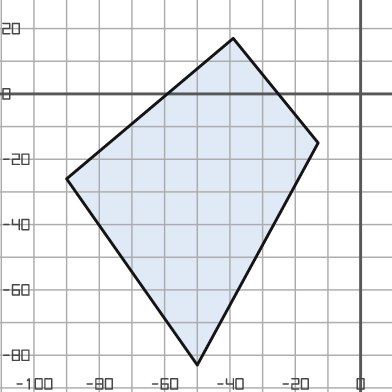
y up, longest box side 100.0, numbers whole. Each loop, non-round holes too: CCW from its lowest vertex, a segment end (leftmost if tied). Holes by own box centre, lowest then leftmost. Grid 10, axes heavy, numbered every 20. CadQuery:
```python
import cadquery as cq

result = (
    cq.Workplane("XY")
    .moveTo(-50.0, -83.0)
    .lineTo(-13.0, -15.0)
    .lineTo(-39.0, 17.0)
    .lineTo(-90.0, -26.0)
    .close()
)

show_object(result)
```